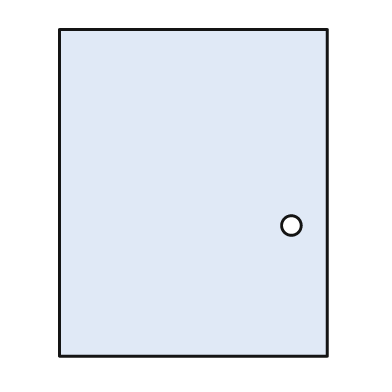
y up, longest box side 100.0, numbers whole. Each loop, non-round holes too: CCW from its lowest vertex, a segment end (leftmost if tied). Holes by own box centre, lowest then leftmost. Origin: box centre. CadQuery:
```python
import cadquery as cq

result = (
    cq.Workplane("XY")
    .moveTo(-41.0, -50.0)
    .lineTo(41.0, -50.0)
    .lineTo(41.0, 50.0)
    .lineTo(-41.0, 50.0)
    .close()
    .moveTo(30.0, -10.0)
    .circle(3.0)
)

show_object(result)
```